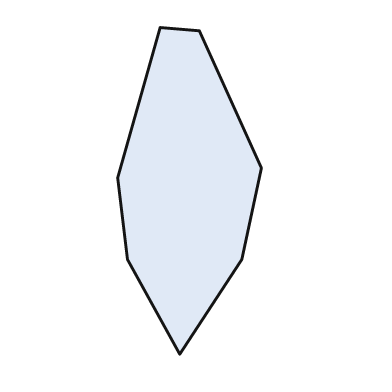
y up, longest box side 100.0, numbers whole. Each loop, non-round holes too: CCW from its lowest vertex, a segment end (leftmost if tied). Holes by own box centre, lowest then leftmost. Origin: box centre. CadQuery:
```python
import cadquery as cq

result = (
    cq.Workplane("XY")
    .moveTo(-3.0, -50.0)
    .lineTo(16.0, -21.0)
    .lineTo(22.0, 7.0)
    .lineTo(3.0, 49.0)
    .lineTo(-9.0, 50.0)
    .lineTo(-22.0, 4.0)
    .lineTo(-19.0, -21.0)
    .close()
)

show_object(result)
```